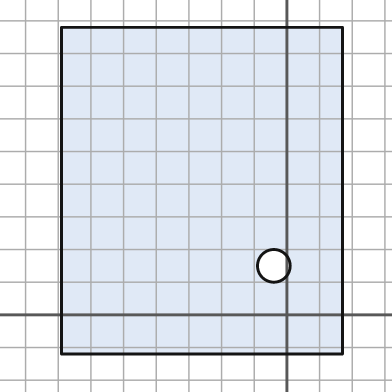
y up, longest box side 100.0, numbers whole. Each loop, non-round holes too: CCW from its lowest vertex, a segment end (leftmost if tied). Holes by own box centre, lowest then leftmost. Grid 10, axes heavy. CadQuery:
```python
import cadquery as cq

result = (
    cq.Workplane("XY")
    .moveTo(-69.0, -12.0)
    .lineTo(17.0, -12.0)
    .lineTo(17.0, 88.0)
    .lineTo(-69.0, 88.0)
    .close()
    .moveTo(-4.0, 15.0)
    .circle(5.0)
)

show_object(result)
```